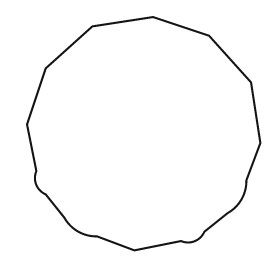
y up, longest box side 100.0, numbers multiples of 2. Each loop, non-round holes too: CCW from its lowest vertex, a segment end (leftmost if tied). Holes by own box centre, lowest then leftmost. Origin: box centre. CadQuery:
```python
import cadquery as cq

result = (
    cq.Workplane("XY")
    .moveTo(-4.0, -50.0)
    .lineTo(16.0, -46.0)
    .threePointArc((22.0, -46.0), (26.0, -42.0))
    .lineTo(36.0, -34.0)
    .threePointArc((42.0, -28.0), (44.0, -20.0))
    .lineTo(50.0, -4.0)
    .lineTo(46.0, 22.0)
    .lineTo(28.0, 42.0)
    .lineTo(4.0, 50.0)
    .lineTo(-22.0, 46.0)
    .lineTo(-42.0, 28.0)
    .lineTo(-50.0, 4.0)
    .lineTo(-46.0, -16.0)
    .threePointArc((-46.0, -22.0), (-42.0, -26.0))
    .lineTo(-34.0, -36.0)
    .threePointArc((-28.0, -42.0), (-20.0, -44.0))
    .close()
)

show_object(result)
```